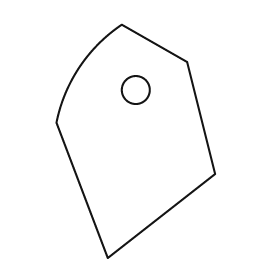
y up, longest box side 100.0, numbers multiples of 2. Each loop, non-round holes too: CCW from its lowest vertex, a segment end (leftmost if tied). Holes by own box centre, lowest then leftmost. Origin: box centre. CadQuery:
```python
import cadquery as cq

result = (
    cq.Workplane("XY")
    .moveTo(-12.0, -50.0)
    .lineTo(34.0, -14.0)
    .lineTo(22.0, 34.0)
    .lineTo(-6.0, 50.0)
    .threePointArc((-24.0, 32.0), (-34.0, 8.0))
    .close()
    .moveTo(0.0, 22.0)
    .circle(6.0)
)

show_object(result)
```